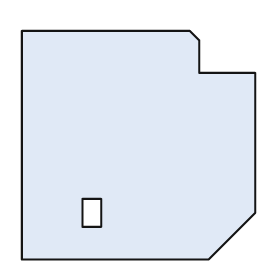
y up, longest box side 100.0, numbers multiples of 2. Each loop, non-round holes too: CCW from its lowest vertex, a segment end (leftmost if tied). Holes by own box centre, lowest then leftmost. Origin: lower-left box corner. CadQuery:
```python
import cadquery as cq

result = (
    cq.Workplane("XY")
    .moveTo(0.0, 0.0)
    .lineTo(80.0, 0.0)
    .lineTo(100.0, 20.0)
    .lineTo(100.0, 80.0)
    .lineTo(76.0, 80.0)
    .lineTo(76.0, 94.0)
    .lineTo(72.0, 98.0)
    .lineTo(0.0, 98.0)
    .close()
    .moveTo(26.0, 14.0)
    .lineTo(34.0, 14.0)
    .lineTo(34.0, 26.0)
    .lineTo(26.0, 26.0)
    .close()
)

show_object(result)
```